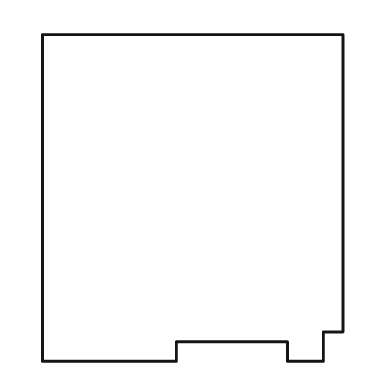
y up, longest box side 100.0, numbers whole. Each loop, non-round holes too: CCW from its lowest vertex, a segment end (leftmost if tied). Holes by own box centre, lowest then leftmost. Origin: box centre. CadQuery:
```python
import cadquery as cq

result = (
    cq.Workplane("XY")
    .moveTo(-46.0, -50.0)
    .lineTo(-5.0, -50.0)
    .lineTo(-5.0, -44.0)
    .lineTo(29.0, -44.0)
    .lineTo(29.0, -50.0)
    .lineTo(40.0, -50.0)
    .lineTo(40.0, -41.0)
    .lineTo(46.0, -41.0)
    .lineTo(46.0, 50.0)
    .lineTo(-46.0, 50.0)
    .close()
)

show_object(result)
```